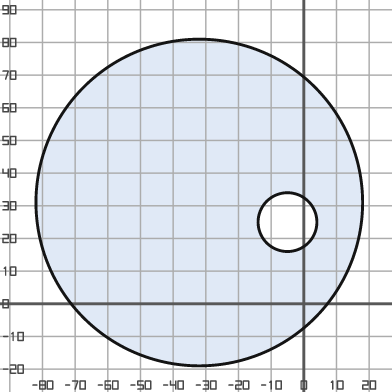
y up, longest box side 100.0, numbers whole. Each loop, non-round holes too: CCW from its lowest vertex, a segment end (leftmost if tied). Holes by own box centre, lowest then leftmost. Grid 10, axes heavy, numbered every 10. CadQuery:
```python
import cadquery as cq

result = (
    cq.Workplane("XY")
    .moveTo(-32.0, 31.0)
    .circle(50.0)
    .moveTo(-5.0, 25.0)
    .circle(9.0)
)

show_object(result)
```